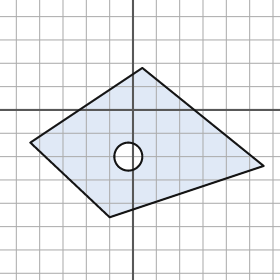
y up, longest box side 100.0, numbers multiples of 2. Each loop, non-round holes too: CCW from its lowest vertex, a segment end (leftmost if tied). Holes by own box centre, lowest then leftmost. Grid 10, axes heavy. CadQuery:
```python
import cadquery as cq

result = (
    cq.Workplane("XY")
    .moveTo(-10.0, -46.0)
    .lineTo(56.0, -24.0)
    .lineTo(4.0, 18.0)
    .lineTo(-44.0, -14.0)
    .close()
    .moveTo(-2.0, -20.0)
    .circle(6.0)
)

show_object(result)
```